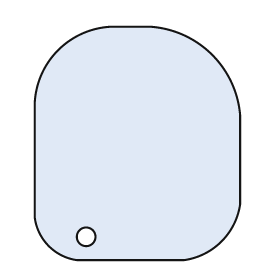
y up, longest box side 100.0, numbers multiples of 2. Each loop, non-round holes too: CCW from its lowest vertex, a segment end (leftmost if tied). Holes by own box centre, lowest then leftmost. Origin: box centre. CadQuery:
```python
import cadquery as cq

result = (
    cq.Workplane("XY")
    .moveTo(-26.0, -50.0)
    .lineTo(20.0, -50.0)
    .threePointArc((36.0, -42.0), (44.0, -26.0))
    .lineTo(44.0, 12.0)
    .threePointArc((32.0, 38.0), (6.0, 50.0))
    .lineTo(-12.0, 50.0)
    .threePointArc((-34.0, 40.0), (-44.0, 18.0))
    .lineTo(-44.0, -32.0)
    .threePointArc((-38.0, -44.0), (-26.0, -50.0))
    .close()
    .moveTo(-22.0, -40.0)
    .circle(4.0)
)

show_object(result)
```